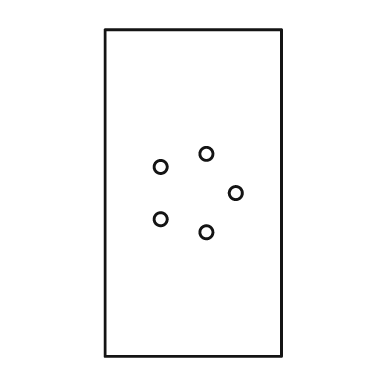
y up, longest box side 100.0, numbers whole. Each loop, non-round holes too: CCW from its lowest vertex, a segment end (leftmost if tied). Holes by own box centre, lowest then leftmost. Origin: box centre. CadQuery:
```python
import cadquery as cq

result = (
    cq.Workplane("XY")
    .moveTo(-27.0, -50.0)
    .lineTo(27.0, -50.0)
    .lineTo(27.0, 50.0)
    .lineTo(-27.0, 50.0)
    .close()
    .moveTo(4.0, -12.0)
    .circle(2.0)
    .moveTo(-10.0, -8.0)
    .circle(2.0)
    .moveTo(13.0, 0.0)
    .circle(2.0)
    .moveTo(-10.0, 8.0)
    .circle(2.0)
    .moveTo(4.0, 12.0)
    .circle(2.0)
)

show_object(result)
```